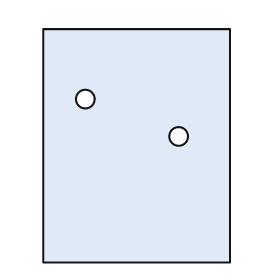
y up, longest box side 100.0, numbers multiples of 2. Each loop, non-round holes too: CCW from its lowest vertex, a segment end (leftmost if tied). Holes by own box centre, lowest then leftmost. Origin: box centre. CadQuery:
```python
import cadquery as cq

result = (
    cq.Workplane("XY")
    .moveTo(-40.0, -50.0)
    .lineTo(40.0, -50.0)
    .lineTo(40.0, 50.0)
    .lineTo(-40.0, 50.0)
    .close()
    .moveTo(18.0, 4.0)
    .circle(4.0)
    .moveTo(-22.0, 20.0)
    .circle(4.0)
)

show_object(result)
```